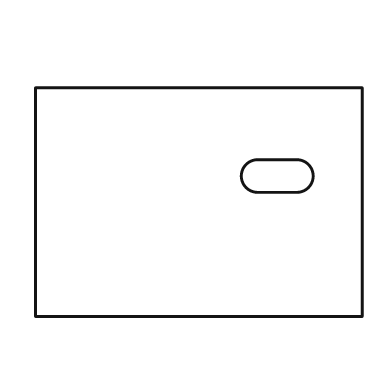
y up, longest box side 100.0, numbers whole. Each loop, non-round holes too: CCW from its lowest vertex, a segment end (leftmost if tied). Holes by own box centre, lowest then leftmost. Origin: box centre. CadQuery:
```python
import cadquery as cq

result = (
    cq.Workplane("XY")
    .moveTo(-50.0, -35.0)
    .lineTo(50.0, -35.0)
    .lineTo(50.0, 35.0)
    .lineTo(-50.0, 35.0)
    .close()
    .moveTo(18.0, 3.0)
    .lineTo(30.0, 3.0)
    .threePointArc((35.0, 8.0), (30.0, 13.0))
    .lineTo(18.0, 13.0)
    .threePointArc((13.0, 8.0), (18.0, 3.0))
    .close()
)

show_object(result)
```